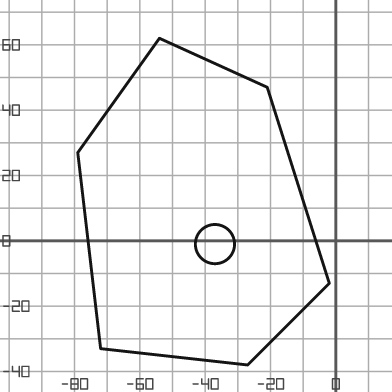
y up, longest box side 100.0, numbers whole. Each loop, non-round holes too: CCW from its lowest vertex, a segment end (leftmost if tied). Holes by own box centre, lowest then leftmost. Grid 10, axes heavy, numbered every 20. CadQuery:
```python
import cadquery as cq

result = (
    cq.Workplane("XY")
    .moveTo(-27.0, -38.0)
    .lineTo(-2.0, -13.0)
    .lineTo(-21.0, 47.0)
    .lineTo(-54.0, 62.0)
    .lineTo(-79.0, 27.0)
    .lineTo(-72.0, -33.0)
    .close()
    .moveTo(-37.0, -1.0)
    .circle(6.0)
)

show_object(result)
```